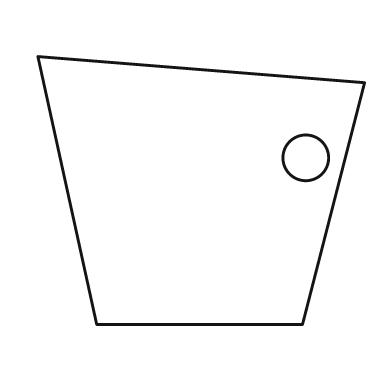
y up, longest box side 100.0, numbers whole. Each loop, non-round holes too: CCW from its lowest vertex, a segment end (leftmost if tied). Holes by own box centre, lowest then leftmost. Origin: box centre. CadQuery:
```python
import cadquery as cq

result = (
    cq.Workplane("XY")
    .moveTo(-32.0, -41.0)
    .lineTo(31.0, -41.0)
    .lineTo(50.0, 33.0)
    .lineTo(-50.0, 41.0)
    .close()
    .moveTo(32.0, 10.0)
    .circle(7.0)
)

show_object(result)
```